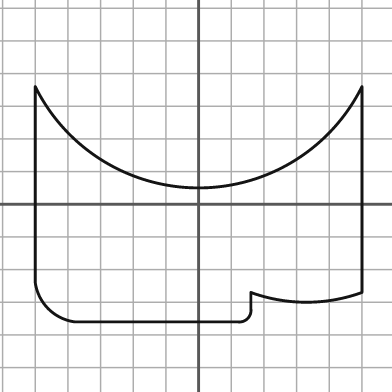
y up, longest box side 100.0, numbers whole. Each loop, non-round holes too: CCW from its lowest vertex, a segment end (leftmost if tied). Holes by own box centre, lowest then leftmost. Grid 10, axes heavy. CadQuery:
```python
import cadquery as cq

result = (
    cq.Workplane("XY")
    .moveTo(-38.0, -36.0)
    .lineTo(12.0, -36.0)
    .threePointArc((15.0, -35.0), (16.0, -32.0))
    .lineTo(16.0, -27.0)
    .threePointArc((33.0, -30.0), (50.0, -27.0))
    .lineTo(50.0, 36.0)
    .threePointArc((0.0, 5.0), (-50.0, 36.0))
    .lineTo(-50.0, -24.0)
    .threePointArc((-46.0, -32.0), (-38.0, -36.0))
    .close()
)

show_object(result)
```